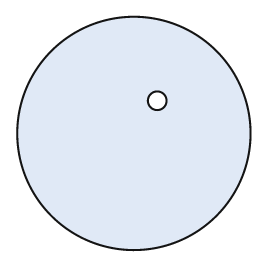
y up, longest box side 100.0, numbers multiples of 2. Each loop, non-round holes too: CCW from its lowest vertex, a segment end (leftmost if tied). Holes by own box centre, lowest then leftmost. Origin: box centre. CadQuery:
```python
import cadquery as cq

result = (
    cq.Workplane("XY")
    .moveTo(0.0, 0.0)
    .circle(50.0)
    .moveTo(10.0, 14.0)
    .circle(4.0)
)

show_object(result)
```